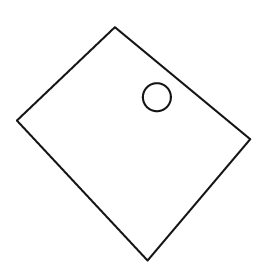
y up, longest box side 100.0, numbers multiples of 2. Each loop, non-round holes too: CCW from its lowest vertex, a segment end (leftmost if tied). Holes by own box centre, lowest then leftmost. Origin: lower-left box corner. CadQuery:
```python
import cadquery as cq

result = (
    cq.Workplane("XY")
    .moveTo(56.0, 0.0)
    .lineTo(100.0, 52.0)
    .lineTo(42.0, 100.0)
    .lineTo(0.0, 60.0)
    .close()
    .moveTo(60.0, 70.0)
    .circle(6.0)
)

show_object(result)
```